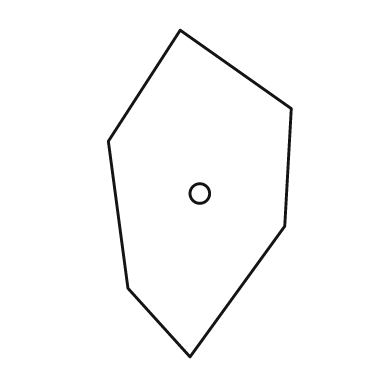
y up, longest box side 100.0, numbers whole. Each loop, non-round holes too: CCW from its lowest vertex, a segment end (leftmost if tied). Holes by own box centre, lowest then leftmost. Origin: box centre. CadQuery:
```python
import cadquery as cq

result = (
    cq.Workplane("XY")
    .moveTo(-3.0, -50.0)
    .lineTo(26.0, -10.0)
    .lineTo(28.0, 26.0)
    .lineTo(-6.0, 50.0)
    .lineTo(-28.0, 16.0)
    .lineTo(-22.0, -29.0)
    .close()
    .moveTo(0.0, 0.0)
    .circle(3.0)
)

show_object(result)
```